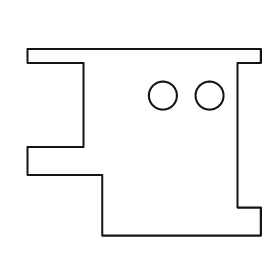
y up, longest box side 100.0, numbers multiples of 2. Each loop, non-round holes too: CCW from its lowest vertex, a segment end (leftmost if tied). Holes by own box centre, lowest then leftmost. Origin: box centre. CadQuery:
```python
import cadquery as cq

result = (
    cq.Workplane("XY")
    .moveTo(-18.0, -40.0)
    .lineTo(50.0, -40.0)
    .lineTo(50.0, -28.0)
    .lineTo(40.0, -28.0)
    .lineTo(40.0, 34.0)
    .lineTo(50.0, 34.0)
    .lineTo(50.0, 40.0)
    .lineTo(-50.0, 40.0)
    .lineTo(-50.0, 34.0)
    .lineTo(-26.0, 34.0)
    .lineTo(-26.0, -2.0)
    .lineTo(-50.0, -2.0)
    .lineTo(-50.0, -14.0)
    .lineTo(-18.0, -14.0)
    .close()
    .moveTo(8.0, 20.0)
    .circle(6.0)
    .moveTo(28.0, 20.0)
    .circle(6.0)
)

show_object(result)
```